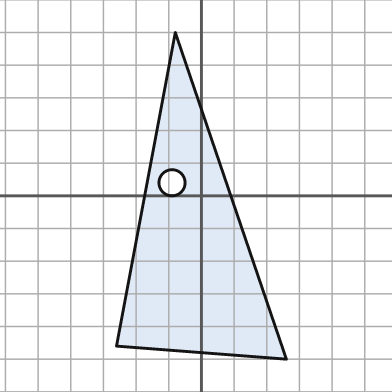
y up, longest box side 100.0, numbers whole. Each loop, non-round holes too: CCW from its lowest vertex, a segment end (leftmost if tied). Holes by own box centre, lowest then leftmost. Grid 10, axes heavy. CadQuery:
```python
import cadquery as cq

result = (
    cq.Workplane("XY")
    .moveTo(26.0, -50.0)
    .lineTo(-8.0, 50.0)
    .lineTo(-26.0, -46.0)
    .close()
    .moveTo(-9.0, 4.0)
    .circle(4.0)
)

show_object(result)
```